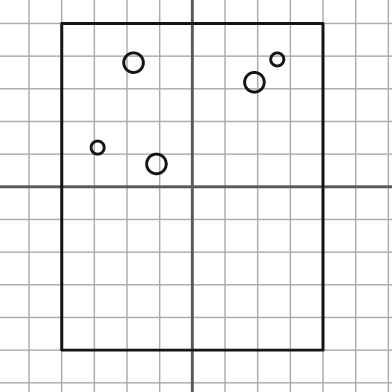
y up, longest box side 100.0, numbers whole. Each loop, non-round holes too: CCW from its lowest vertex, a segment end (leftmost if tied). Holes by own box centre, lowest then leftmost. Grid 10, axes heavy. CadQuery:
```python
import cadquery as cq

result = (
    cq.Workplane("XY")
    .moveTo(-40.0, -50.0)
    .lineTo(40.0, -50.0)
    .lineTo(40.0, 50.0)
    .lineTo(-40.0, 50.0)
    .close()
    .moveTo(-11.0, 7.0)
    .circle(3.0)
    .moveTo(-29.0, 12.0)
    .circle(2.0)
    .moveTo(19.0, 32.0)
    .circle(3.0)
    .moveTo(-18.0, 38.0)
    .circle(3.0)
    .moveTo(26.0, 39.0)
    .circle(2.0)
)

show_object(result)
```